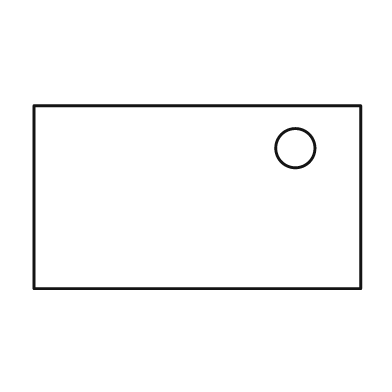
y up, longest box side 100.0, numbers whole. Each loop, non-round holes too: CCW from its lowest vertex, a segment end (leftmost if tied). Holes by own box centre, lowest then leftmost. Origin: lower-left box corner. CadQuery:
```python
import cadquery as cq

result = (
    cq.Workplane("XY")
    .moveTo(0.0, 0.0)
    .lineTo(100.0, 0.0)
    .lineTo(100.0, 56.0)
    .lineTo(0.0, 56.0)
    .close()
    .moveTo(80.0, 43.0)
    .circle(6.0)
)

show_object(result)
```